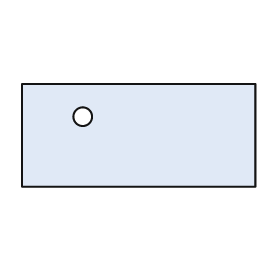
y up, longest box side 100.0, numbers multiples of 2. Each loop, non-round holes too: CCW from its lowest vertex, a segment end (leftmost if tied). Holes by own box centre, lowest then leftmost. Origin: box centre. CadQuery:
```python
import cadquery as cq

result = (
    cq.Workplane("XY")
    .moveTo(-50.0, -22.0)
    .lineTo(50.0, -22.0)
    .lineTo(50.0, 22.0)
    .lineTo(-50.0, 22.0)
    .close()
    .moveTo(-24.0, 8.0)
    .circle(4.0)
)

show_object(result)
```